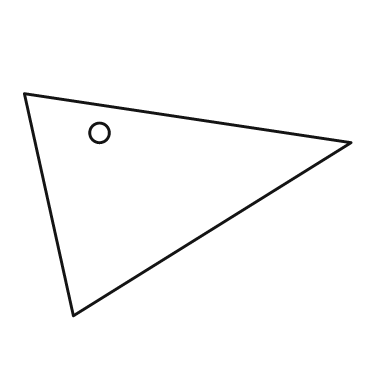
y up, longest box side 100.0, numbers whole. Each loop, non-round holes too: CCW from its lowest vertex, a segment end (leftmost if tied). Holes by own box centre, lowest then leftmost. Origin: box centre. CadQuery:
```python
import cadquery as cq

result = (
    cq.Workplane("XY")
    .moveTo(-35.0, -34.0)
    .lineTo(50.0, 19.0)
    .lineTo(-50.0, 34.0)
    .close()
    .moveTo(-27.0, 22.0)
    .circle(3.0)
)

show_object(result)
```